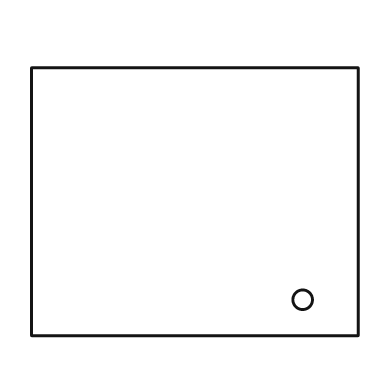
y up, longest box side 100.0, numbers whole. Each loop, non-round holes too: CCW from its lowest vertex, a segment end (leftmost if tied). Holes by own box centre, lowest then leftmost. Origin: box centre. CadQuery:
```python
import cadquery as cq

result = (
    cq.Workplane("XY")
    .moveTo(-50.0, -41.0)
    .lineTo(50.0, -41.0)
    .lineTo(50.0, 41.0)
    .lineTo(-50.0, 41.0)
    .close()
    .moveTo(33.0, -30.0)
    .circle(3.0)
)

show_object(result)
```